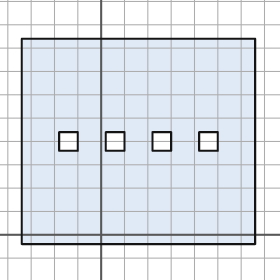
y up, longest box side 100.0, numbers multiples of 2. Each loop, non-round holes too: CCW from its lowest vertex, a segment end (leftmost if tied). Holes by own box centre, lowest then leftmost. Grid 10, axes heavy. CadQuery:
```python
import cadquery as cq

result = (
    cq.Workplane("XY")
    .moveTo(-34.0, -4.0)
    .lineTo(66.0, -4.0)
    .lineTo(66.0, 84.0)
    .lineTo(-34.0, 84.0)
    .close()
    .moveTo(-18.0, 36.0)
    .lineTo(-10.0, 36.0)
    .lineTo(-10.0, 44.0)
    .lineTo(-18.0, 44.0)
    .close()
    .moveTo(2.0, 36.0)
    .lineTo(10.0, 36.0)
    .lineTo(10.0, 44.0)
    .lineTo(2.0, 44.0)
    .close()
    .moveTo(22.0, 36.0)
    .lineTo(30.0, 36.0)
    .lineTo(30.0, 44.0)
    .lineTo(22.0, 44.0)
    .close()
    .moveTo(42.0, 36.0)
    .lineTo(50.0, 36.0)
    .lineTo(50.0, 44.0)
    .lineTo(42.0, 44.0)
    .close()
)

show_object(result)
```